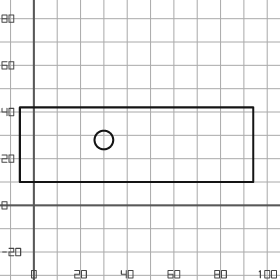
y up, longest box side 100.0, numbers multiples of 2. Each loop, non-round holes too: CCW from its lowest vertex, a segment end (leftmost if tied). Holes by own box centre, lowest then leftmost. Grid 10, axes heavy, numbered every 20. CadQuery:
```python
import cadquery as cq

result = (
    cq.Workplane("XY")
    .moveTo(-6.0, 10.0)
    .lineTo(94.0, 10.0)
    .lineTo(94.0, 42.0)
    .lineTo(-6.0, 42.0)
    .close()
    .moveTo(30.0, 28.0)
    .circle(4.0)
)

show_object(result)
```